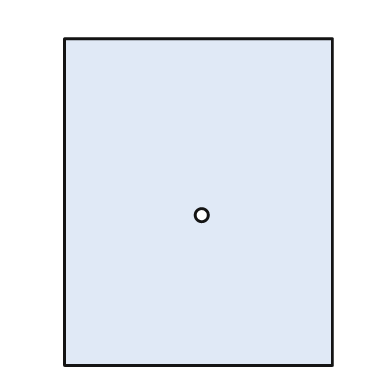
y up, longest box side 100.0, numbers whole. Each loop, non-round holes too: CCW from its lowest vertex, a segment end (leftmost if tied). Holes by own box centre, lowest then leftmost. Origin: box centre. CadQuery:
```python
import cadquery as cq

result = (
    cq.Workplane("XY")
    .moveTo(-41.0, -50.0)
    .lineTo(41.0, -50.0)
    .lineTo(41.0, 50.0)
    .lineTo(-41.0, 50.0)
    .close()
    .moveTo(1.0, -4.0)
    .circle(2.0)
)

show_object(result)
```